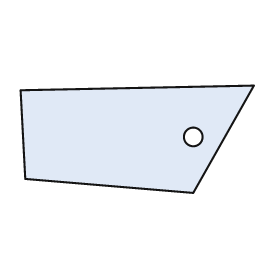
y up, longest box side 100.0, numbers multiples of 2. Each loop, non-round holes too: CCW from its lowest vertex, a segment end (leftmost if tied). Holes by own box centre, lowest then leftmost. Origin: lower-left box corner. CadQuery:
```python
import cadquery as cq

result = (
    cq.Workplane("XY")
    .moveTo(74.0, 0.0)
    .lineTo(100.0, 46.0)
    .lineTo(0.0, 44.0)
    .lineTo(2.0, 6.0)
    .close()
    .moveTo(74.0, 24.0)
    .circle(4.0)
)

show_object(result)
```